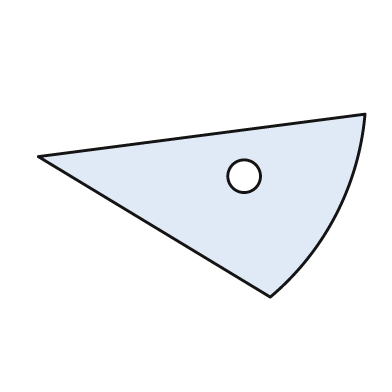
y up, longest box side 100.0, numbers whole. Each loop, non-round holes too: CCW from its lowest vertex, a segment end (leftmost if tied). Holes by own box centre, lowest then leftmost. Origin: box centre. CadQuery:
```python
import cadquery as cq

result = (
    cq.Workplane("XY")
    .moveTo(21.0, -28.0)
    .threePointArc((41.0, -3.0), (50.0, 28.0))
    .lineTo(-50.0, 15.0)
    .close()
    .moveTo(13.0, 9.0)
    .circle(5.0)
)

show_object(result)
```